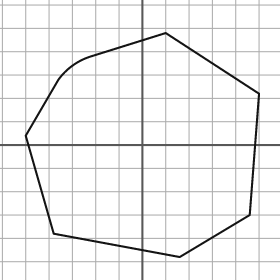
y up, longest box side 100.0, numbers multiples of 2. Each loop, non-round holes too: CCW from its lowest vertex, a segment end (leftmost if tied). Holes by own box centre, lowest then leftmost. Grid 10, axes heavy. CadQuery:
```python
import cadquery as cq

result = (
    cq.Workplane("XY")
    .moveTo(16.0, -48.0)
    .lineTo(46.0, -30.0)
    .lineTo(50.0, 22.0)
    .lineTo(10.0, 48.0)
    .lineTo(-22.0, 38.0)
    .threePointArc((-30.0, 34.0), (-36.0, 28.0))
    .lineTo(-50.0, 4.0)
    .lineTo(-38.0, -38.0)
    .close()
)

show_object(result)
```